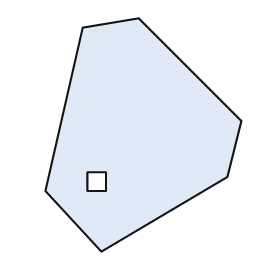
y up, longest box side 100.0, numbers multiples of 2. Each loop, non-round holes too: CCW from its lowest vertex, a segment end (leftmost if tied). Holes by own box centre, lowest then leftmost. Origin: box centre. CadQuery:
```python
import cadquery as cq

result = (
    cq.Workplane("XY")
    .moveTo(-18.0, -50.0)
    .lineTo(36.0, -18.0)
    .lineTo(42.0, 6.0)
    .lineTo(-2.0, 50.0)
    .lineTo(-26.0, 46.0)
    .lineTo(-42.0, -24.0)
    .close()
    .moveTo(-24.0, -24.0)
    .lineTo(-16.0, -24.0)
    .lineTo(-16.0, -16.0)
    .lineTo(-24.0, -16.0)
    .close()
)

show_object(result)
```